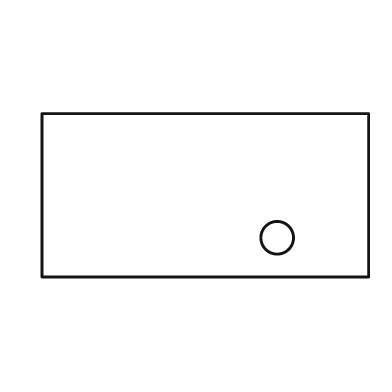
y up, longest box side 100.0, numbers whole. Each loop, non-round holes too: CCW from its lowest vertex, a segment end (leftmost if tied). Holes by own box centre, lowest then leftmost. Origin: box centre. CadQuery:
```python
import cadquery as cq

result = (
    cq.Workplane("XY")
    .moveTo(-50.0, -25.0)
    .lineTo(50.0, -25.0)
    .lineTo(50.0, 25.0)
    .lineTo(-50.0, 25.0)
    .close()
    .moveTo(22.0, -13.0)
    .circle(5.0)
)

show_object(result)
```